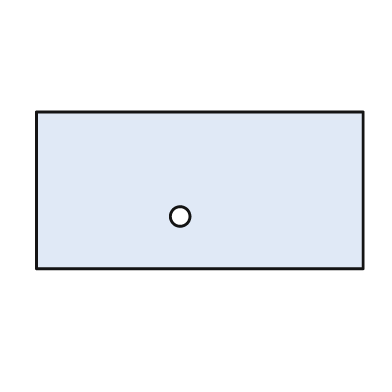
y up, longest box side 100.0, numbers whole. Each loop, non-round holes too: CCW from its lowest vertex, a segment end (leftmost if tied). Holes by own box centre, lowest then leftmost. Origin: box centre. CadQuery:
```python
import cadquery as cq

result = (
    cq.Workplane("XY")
    .moveTo(-50.0, -24.0)
    .lineTo(50.0, -24.0)
    .lineTo(50.0, 24.0)
    .lineTo(-50.0, 24.0)
    .close()
    .moveTo(-6.0, -8.0)
    .circle(3.0)
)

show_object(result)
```